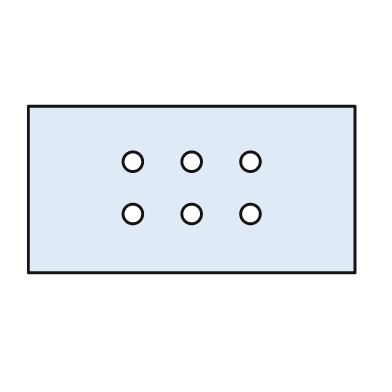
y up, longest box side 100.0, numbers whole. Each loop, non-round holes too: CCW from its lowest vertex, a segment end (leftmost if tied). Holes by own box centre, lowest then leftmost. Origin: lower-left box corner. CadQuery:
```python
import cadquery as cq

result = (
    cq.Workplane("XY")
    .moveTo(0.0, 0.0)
    .lineTo(100.0, 0.0)
    .lineTo(100.0, 51.0)
    .lineTo(0.0, 51.0)
    .close()
    .moveTo(32.0, 18.0)
    .circle(3.0)
    .moveTo(50.0, 18.0)
    .circle(3.0)
    .moveTo(68.0, 18.0)
    .circle(3.0)
    .moveTo(32.0, 34.0)
    .circle(3.0)
    .moveTo(50.0, 34.0)
    .circle(3.0)
    .moveTo(68.0, 34.0)
    .circle(3.0)
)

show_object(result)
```